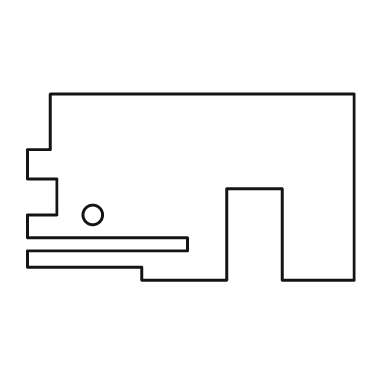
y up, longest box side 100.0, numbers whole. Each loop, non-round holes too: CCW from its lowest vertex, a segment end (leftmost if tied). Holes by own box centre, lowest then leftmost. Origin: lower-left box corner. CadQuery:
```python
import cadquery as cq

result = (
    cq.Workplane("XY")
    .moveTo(35.0, 0.0)
    .lineTo(61.0, 0.0)
    .lineTo(61.0, 28.0)
    .lineTo(78.0, 28.0)
    .lineTo(78.0, 0.0)
    .lineTo(100.0, 0.0)
    .lineTo(100.0, 57.0)
    .lineTo(7.0, 57.0)
    .lineTo(7.0, 40.0)
    .lineTo(0.0, 40.0)
    .lineTo(0.0, 31.0)
    .lineTo(9.0, 31.0)
    .lineTo(9.0, 20.0)
    .lineTo(0.0, 20.0)
    .lineTo(0.0, 13.0)
    .lineTo(49.0, 13.0)
    .lineTo(49.0, 9.0)
    .lineTo(0.0, 9.0)
    .lineTo(0.0, 4.0)
    .lineTo(35.0, 4.0)
    .close()
    .moveTo(20.0, 20.0)
    .circle(3.0)
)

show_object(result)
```